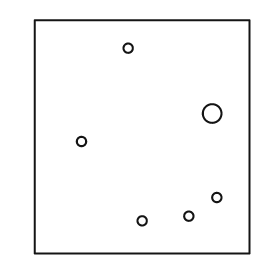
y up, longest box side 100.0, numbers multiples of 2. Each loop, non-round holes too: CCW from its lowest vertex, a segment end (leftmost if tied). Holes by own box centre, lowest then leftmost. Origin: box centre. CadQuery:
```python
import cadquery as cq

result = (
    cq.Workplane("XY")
    .moveTo(-46.0, -50.0)
    .lineTo(46.0, -50.0)
    .lineTo(46.0, 50.0)
    .lineTo(-46.0, 50.0)
    .close()
    .moveTo(0.0, -36.0)
    .circle(2.0)
    .moveTo(20.0, -34.0)
    .circle(2.0)
    .moveTo(32.0, -26.0)
    .circle(2.0)
    .moveTo(-26.0, -2.0)
    .circle(2.0)
    .moveTo(30.0, 10.0)
    .circle(4.0)
    .moveTo(-6.0, 38.0)
    .circle(2.0)
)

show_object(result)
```